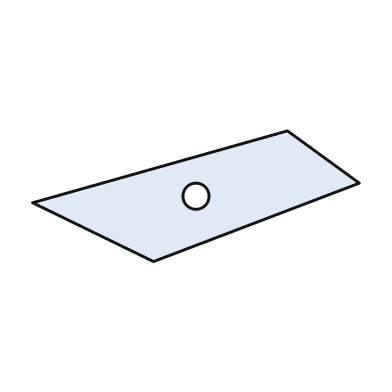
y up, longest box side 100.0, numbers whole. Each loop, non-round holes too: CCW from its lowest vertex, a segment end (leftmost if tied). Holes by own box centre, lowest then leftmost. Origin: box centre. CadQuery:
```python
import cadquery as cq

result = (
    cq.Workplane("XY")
    .moveTo(-13.0, -20.0)
    .lineTo(50.0, 4.0)
    .lineTo(28.0, 20.0)
    .lineTo(-50.0, -2.0)
    .close()
    .moveTo(0.0, 0.0)
    .circle(4.0)
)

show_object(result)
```